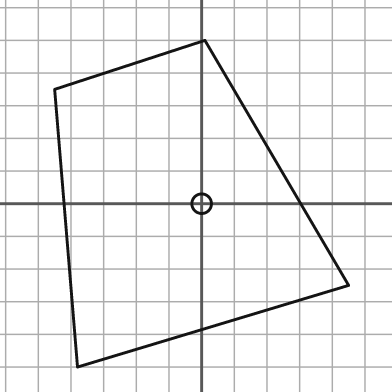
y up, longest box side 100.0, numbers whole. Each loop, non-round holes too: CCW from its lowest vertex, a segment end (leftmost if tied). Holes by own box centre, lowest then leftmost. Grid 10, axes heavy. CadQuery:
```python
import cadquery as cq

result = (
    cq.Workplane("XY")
    .moveTo(-38.0, -50.0)
    .lineTo(45.0, -25.0)
    .lineTo(1.0, 50.0)
    .lineTo(-45.0, 35.0)
    .close()
    .moveTo(0.0, 0.0)
    .circle(3.0)
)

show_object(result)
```